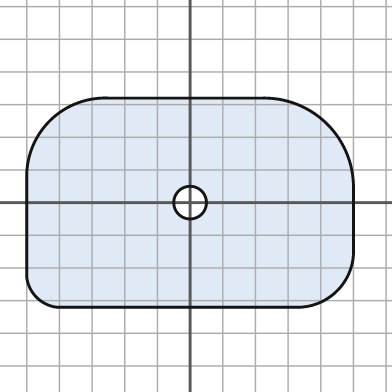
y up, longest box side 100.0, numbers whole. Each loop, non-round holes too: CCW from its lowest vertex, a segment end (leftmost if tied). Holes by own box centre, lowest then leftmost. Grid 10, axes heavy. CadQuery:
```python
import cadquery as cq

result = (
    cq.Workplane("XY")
    .moveTo(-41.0, -32.0)
    .lineTo(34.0, -32.0)
    .threePointArc((45.0, -27.0), (50.0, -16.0))
    .lineTo(50.0, 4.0)
    .threePointArc((42.0, 24.0), (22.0, 32.0))
    .lineTo(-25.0, 32.0)
    .threePointArc((-43.0, 25.0), (-50.0, 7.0))
    .lineTo(-50.0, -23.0)
    .threePointArc((-47.0, -29.0), (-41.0, -32.0))
    .close()
    .moveTo(0.0, 0.0)
    .circle(5.0)
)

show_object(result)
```